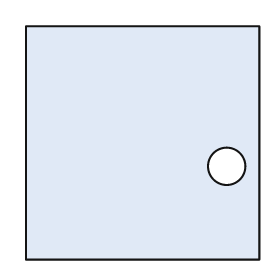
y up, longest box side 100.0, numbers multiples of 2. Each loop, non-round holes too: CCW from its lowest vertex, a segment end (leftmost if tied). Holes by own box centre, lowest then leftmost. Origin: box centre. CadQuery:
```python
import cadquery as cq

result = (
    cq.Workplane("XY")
    .moveTo(-50.0, -50.0)
    .lineTo(50.0, -50.0)
    .lineTo(50.0, 50.0)
    .lineTo(-50.0, 50.0)
    .close()
    .moveTo(36.0, -10.0)
    .circle(8.0)
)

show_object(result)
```